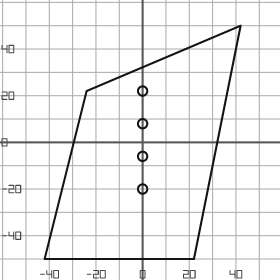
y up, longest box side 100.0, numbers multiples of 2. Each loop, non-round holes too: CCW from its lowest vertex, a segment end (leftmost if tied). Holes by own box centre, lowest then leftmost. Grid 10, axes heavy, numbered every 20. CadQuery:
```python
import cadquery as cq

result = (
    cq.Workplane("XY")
    .moveTo(-42.0, -50.0)
    .lineTo(22.0, -50.0)
    .lineTo(42.0, 50.0)
    .lineTo(-24.0, 22.0)
    .close()
    .moveTo(0.0, -20.0)
    .circle(2.0)
    .moveTo(0.0, -6.0)
    .circle(2.0)
    .moveTo(0.0, 8.0)
    .circle(2.0)
    .moveTo(0.0, 22.0)
    .circle(2.0)
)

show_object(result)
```